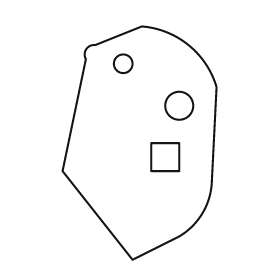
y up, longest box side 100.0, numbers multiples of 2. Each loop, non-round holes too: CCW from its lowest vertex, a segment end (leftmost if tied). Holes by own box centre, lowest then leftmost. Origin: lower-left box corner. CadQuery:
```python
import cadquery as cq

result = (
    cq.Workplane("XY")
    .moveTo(30.0, 0.0)
    .lineTo(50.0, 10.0)
    .threePointArc((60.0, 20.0), (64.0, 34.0))
    .lineTo(66.0, 74.0)
    .threePointArc((54.0, 92.0), (34.0, 100.0))
    .lineTo(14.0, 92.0)
    .threePointArc((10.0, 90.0), (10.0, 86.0))
    .lineTo(0.0, 38.0)
    .close()
    .moveTo(38.0, 38.0)
    .lineTo(50.0, 38.0)
    .lineTo(50.0, 50.0)
    .lineTo(38.0, 50.0)
    .close()
    .moveTo(50.0, 66.0)
    .circle(6.0)
    .moveTo(26.0, 84.0)
    .circle(4.0)
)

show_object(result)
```